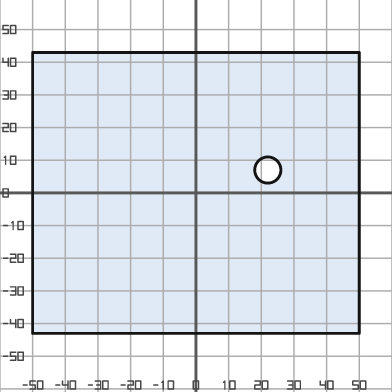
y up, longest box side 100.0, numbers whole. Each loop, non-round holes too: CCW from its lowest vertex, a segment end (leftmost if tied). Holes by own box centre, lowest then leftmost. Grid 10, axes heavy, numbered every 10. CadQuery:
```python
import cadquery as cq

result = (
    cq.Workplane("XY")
    .moveTo(-50.0, -43.0)
    .lineTo(50.0, -43.0)
    .lineTo(50.0, 43.0)
    .lineTo(-50.0, 43.0)
    .close()
    .moveTo(22.0, 7.0)
    .circle(4.0)
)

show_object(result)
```